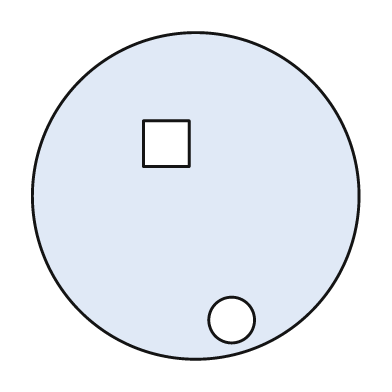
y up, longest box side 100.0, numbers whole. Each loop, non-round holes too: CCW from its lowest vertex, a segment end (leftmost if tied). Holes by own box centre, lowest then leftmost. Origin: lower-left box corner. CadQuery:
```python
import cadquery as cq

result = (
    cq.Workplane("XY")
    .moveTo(50.0, 50.0)
    .circle(50.0)
    .moveTo(61.0, 12.0)
    .circle(7.0)
    .moveTo(34.0, 59.0)
    .lineTo(48.0, 59.0)
    .lineTo(48.0, 73.0)
    .lineTo(34.0, 73.0)
    .close()
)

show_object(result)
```